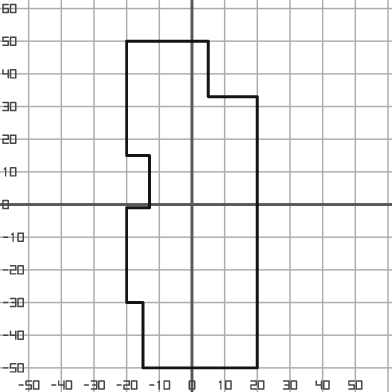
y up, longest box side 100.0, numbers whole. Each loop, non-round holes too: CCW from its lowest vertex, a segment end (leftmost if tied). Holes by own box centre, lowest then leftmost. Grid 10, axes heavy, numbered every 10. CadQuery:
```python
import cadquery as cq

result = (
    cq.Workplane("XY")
    .moveTo(-15.0, -50.0)
    .lineTo(20.0, -50.0)
    .lineTo(20.0, 33.0)
    .lineTo(5.0, 33.0)
    .lineTo(5.0, 50.0)
    .lineTo(-20.0, 50.0)
    .lineTo(-20.0, 15.0)
    .lineTo(-13.0, 15.0)
    .lineTo(-13.0, -1.0)
    .lineTo(-20.0, -1.0)
    .lineTo(-20.0, -30.0)
    .lineTo(-15.0, -30.0)
    .close()
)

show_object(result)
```